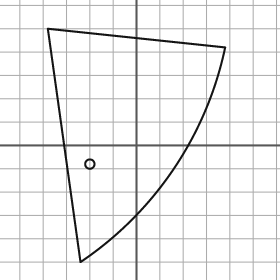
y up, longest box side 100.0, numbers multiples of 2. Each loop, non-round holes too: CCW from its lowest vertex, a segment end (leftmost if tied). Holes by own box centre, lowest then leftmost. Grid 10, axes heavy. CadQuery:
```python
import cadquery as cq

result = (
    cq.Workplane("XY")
    .moveTo(-24.0, -50.0)
    .threePointArc((16.0, -10.0), (38.0, 42.0))
    .lineTo(-38.0, 50.0)
    .close()
    .moveTo(-20.0, -8.0)
    .circle(2.0)
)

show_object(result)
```